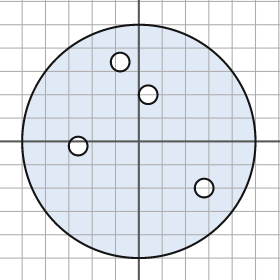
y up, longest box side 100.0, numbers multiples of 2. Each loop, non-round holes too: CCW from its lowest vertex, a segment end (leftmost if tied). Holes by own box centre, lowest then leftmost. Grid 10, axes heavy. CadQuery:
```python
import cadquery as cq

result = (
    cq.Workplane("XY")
    .moveTo(0.0, 0.0)
    .circle(50.0)
    .moveTo(28.0, -20.0)
    .circle(4.0)
    .moveTo(-26.0, -2.0)
    .circle(4.0)
    .moveTo(4.0, 20.0)
    .circle(4.0)
    .moveTo(-8.0, 34.0)
    .circle(4.0)
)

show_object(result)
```